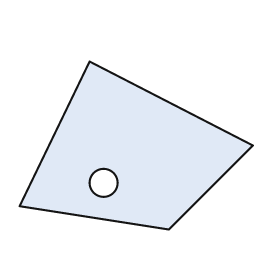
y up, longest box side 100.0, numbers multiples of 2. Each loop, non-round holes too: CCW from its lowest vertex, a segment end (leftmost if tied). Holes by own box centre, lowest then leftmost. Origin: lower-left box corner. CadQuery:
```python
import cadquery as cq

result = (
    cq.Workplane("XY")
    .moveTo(64.0, 0.0)
    .lineTo(100.0, 36.0)
    .lineTo(30.0, 72.0)
    .lineTo(0.0, 10.0)
    .close()
    .moveTo(36.0, 20.0)
    .circle(6.0)
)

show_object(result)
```